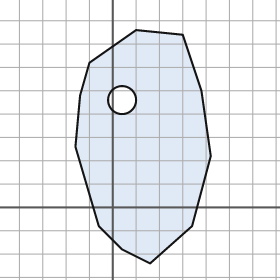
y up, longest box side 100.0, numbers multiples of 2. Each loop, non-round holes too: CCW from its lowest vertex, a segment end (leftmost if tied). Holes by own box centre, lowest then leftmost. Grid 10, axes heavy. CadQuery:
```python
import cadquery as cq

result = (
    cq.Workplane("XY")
    .moveTo(16.0, -24.0)
    .lineTo(34.0, -8.0)
    .lineTo(42.0, 22.0)
    .lineTo(38.0, 50.0)
    .lineTo(30.0, 74.0)
    .lineTo(10.0, 76.0)
    .lineTo(-10.0, 62.0)
    .lineTo(-14.0, 48.0)
    .lineTo(-16.0, 26.0)
    .lineTo(-6.0, -8.0)
    .lineTo(4.0, -18.0)
    .close()
    .moveTo(4.0, 46.0)
    .circle(6.0)
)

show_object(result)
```